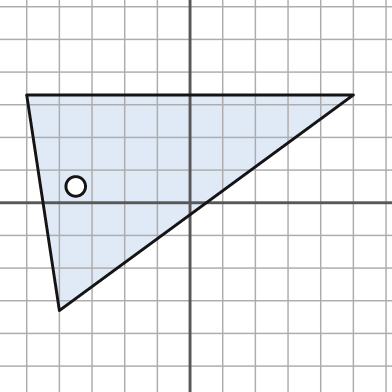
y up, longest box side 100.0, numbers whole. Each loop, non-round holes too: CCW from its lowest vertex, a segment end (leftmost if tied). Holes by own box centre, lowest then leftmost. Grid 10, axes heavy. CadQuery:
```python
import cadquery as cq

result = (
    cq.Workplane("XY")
    .moveTo(-40.0, -33.0)
    .lineTo(50.0, 33.0)
    .lineTo(-50.0, 33.0)
    .close()
    .moveTo(-35.0, 5.0)
    .circle(3.0)
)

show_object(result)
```